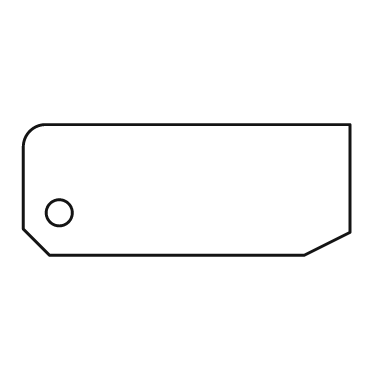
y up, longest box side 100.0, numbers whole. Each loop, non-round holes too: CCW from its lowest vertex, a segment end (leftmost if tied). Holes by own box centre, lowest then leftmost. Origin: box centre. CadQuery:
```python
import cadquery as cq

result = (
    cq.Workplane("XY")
    .moveTo(-42.0, -20.0)
    .lineTo(36.0, -20.0)
    .lineTo(50.0, -13.0)
    .lineTo(50.0, 20.0)
    .lineTo(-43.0, 20.0)
    .threePointArc((-48.0, 18.0), (-50.0, 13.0))
    .lineTo(-50.0, -12.0)
    .close()
    .moveTo(-39.0, -7.0)
    .circle(4.0)
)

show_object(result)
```